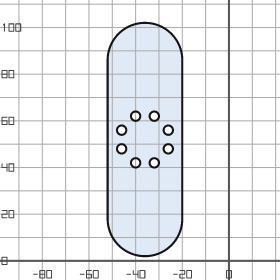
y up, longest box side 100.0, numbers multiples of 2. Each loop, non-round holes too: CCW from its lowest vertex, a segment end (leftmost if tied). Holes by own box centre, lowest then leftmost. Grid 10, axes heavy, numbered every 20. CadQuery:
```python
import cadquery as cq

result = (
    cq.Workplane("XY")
    .moveTo(-52.0, 18.0)
    .threePointArc((-36.0, 2.0), (-20.0, 18.0))
    .lineTo(-20.0, 86.0)
    .threePointArc((-36.0, 102.0), (-52.0, 86.0))
    .close()
    .moveTo(-40.0, 42.0)
    .circle(2.0)
    .moveTo(-32.0, 42.0)
    .circle(2.0)
    .moveTo(-46.0, 48.0)
    .circle(2.0)
    .moveTo(-26.0, 48.0)
    .circle(2.0)
    .moveTo(-46.0, 56.0)
    .circle(2.0)
    .moveTo(-26.0, 56.0)
    .circle(2.0)
    .moveTo(-40.0, 62.0)
    .circle(2.0)
    .moveTo(-32.0, 62.0)
    .circle(2.0)
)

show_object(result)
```